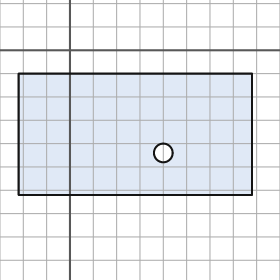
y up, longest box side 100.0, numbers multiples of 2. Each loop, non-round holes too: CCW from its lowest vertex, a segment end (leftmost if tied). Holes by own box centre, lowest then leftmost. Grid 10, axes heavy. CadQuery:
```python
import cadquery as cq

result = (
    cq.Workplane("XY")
    .moveTo(-22.0, -62.0)
    .lineTo(78.0, -62.0)
    .lineTo(78.0, -10.0)
    .lineTo(-22.0, -10.0)
    .close()
    .moveTo(40.0, -44.0)
    .circle(4.0)
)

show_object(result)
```